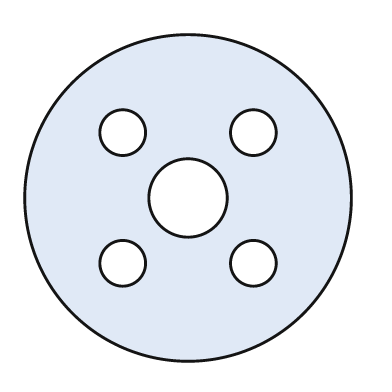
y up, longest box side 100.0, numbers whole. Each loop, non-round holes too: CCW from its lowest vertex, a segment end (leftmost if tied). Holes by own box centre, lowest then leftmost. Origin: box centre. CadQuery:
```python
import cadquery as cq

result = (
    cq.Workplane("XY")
    .moveTo(0.0, 0.0)
    .circle(50.0)
    .moveTo(-20.0, -20.0)
    .circle(7.0)
    .moveTo(20.0, -20.0)
    .circle(7.0)
    .moveTo(0.0, 0.0)
    .circle(12.0)
    .moveTo(-20.0, 20.0)
    .circle(7.0)
    .moveTo(20.0, 20.0)
    .circle(7.0)
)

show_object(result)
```